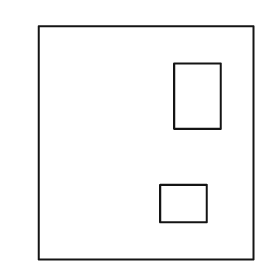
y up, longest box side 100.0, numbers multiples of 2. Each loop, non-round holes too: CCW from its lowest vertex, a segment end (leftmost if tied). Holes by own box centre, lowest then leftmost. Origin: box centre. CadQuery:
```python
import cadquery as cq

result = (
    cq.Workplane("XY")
    .moveTo(-46.0, -50.0)
    .lineTo(46.0, -50.0)
    .lineTo(46.0, 50.0)
    .lineTo(-46.0, 50.0)
    .close()
    .moveTo(6.0, -34.0)
    .lineTo(26.0, -34.0)
    .lineTo(26.0, -18.0)
    .lineTo(6.0, -18.0)
    .close()
    .moveTo(12.0, 6.0)
    .lineTo(32.0, 6.0)
    .lineTo(32.0, 34.0)
    .lineTo(12.0, 34.0)
    .close()
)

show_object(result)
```